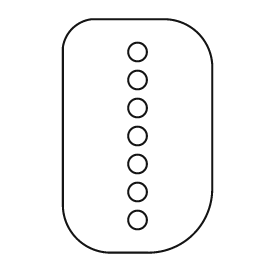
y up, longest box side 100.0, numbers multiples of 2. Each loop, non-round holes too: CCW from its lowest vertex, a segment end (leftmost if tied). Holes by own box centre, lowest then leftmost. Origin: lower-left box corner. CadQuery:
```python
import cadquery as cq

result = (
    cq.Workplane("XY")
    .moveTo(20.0, 0.0)
    .lineTo(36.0, 0.0)
    .threePointArc((56.0, 8.0), (64.0, 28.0))
    .lineTo(64.0, 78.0)
    .threePointArc((58.0, 94.0), (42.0, 100.0))
    .lineTo(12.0, 100.0)
    .threePointArc((4.0, 96.0), (0.0, 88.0))
    .lineTo(0.0, 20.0)
    .threePointArc((6.0, 6.0), (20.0, 0.0))
    .close()
    .moveTo(32.0, 14.0)
    .circle(4.0)
    .moveTo(32.0, 26.0)
    .circle(4.0)
    .moveTo(32.0, 38.0)
    .circle(4.0)
    .moveTo(32.0, 50.0)
    .circle(4.0)
    .moveTo(32.0, 62.0)
    .circle(4.0)
    .moveTo(32.0, 74.0)
    .circle(4.0)
    .moveTo(32.0, 86.0)
    .circle(4.0)
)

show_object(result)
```